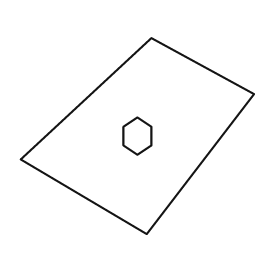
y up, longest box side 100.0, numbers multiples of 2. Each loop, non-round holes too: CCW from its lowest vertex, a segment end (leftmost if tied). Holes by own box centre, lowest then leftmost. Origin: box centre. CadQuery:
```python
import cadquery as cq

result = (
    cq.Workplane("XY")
    .moveTo(4.0, -42.0)
    .lineTo(50.0, 18.0)
    .lineTo(6.0, 42.0)
    .lineTo(-50.0, -10.0)
    .close()
    .moveTo(0.0, -8.0)
    .lineTo(6.0, -4.0)
    .lineTo(6.0, 4.0)
    .lineTo(0.0, 8.0)
    .lineTo(-6.0, 4.0)
    .lineTo(-6.0, -4.0)
    .close()
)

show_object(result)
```